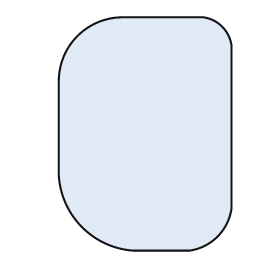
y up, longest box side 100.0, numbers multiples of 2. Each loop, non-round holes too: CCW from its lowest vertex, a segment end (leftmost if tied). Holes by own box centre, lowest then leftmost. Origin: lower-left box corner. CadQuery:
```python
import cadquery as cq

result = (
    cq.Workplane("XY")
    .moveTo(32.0, 0.0)
    .lineTo(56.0, 0.0)
    .threePointArc((68.0, 6.0), (74.0, 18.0))
    .lineTo(74.0, 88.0)
    .threePointArc((70.0, 96.0), (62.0, 100.0))
    .lineTo(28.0, 100.0)
    .threePointArc((8.0, 92.0), (0.0, 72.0))
    .lineTo(0.0, 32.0)
    .threePointArc((10.0, 10.0), (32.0, 0.0))
    .close()
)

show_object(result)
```